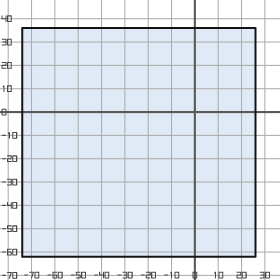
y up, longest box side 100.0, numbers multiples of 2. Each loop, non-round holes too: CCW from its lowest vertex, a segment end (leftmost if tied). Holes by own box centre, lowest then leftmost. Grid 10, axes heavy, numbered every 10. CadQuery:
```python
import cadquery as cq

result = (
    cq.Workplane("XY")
    .moveTo(-74.0, -62.0)
    .lineTo(26.0, -62.0)
    .lineTo(26.0, 36.0)
    .lineTo(-74.0, 36.0)
    .close()
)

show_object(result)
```